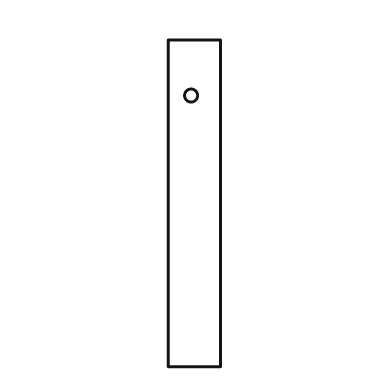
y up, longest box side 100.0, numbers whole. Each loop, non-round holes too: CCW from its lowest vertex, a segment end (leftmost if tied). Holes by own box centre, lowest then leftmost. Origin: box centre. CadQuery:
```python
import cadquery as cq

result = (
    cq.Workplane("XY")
    .moveTo(-8.0, -50.0)
    .lineTo(8.0, -50.0)
    .lineTo(8.0, 50.0)
    .lineTo(-8.0, 50.0)
    .close()
    .moveTo(-1.0, 33.0)
    .circle(2.0)
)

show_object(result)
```